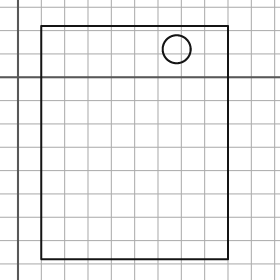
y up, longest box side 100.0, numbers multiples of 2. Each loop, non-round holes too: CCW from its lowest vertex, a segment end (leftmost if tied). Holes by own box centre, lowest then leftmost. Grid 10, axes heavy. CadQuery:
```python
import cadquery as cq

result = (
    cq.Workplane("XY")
    .moveTo(10.0, -78.0)
    .lineTo(90.0, -78.0)
    .lineTo(90.0, 22.0)
    .lineTo(10.0, 22.0)
    .close()
    .moveTo(68.0, 12.0)
    .circle(6.0)
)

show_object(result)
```